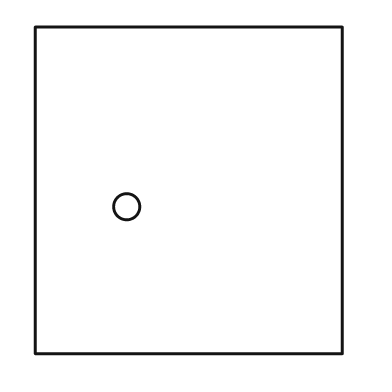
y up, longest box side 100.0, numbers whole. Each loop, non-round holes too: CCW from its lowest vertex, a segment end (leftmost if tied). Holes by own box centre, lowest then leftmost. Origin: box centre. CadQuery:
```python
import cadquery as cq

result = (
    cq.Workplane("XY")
    .moveTo(-47.0, -50.0)
    .lineTo(47.0, -50.0)
    .lineTo(47.0, 50.0)
    .lineTo(-47.0, 50.0)
    .close()
    .moveTo(-19.0, -5.0)
    .circle(4.0)
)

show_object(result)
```